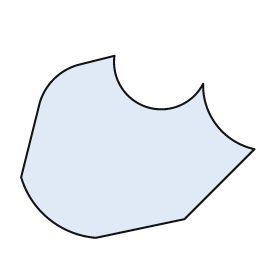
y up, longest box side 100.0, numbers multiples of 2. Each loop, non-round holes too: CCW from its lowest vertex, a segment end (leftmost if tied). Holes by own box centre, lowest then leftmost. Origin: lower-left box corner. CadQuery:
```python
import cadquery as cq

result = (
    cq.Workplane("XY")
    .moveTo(32.0, 0.0)
    .lineTo(70.0, 8.0)
    .lineTo(100.0, 38.0)
    .threePointArc((84.0, 48.0), (78.0, 66.0))
    .threePointArc((54.0, 56.0), (40.0, 78.0))
    .lineTo(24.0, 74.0)
    .threePointArc((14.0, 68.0), (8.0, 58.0))
    .lineTo(0.0, 26.0)
    .threePointArc((12.0, 8.0), (32.0, 0.0))
    .close()
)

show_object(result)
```